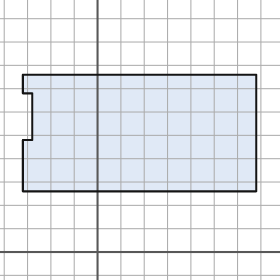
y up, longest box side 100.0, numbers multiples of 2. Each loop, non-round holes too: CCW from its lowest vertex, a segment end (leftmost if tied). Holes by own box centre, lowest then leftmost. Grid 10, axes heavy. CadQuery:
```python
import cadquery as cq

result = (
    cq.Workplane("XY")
    .moveTo(-32.0, 26.0)
    .lineTo(68.0, 26.0)
    .lineTo(68.0, 76.0)
    .lineTo(-32.0, 76.0)
    .lineTo(-32.0, 68.0)
    .lineTo(-28.0, 68.0)
    .lineTo(-28.0, 48.0)
    .lineTo(-32.0, 48.0)
    .close()
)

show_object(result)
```